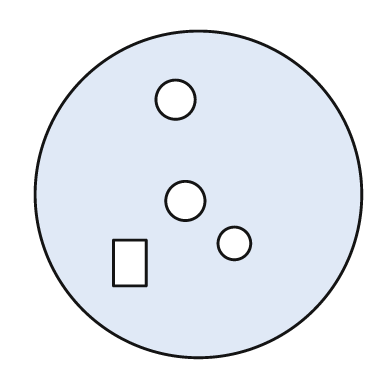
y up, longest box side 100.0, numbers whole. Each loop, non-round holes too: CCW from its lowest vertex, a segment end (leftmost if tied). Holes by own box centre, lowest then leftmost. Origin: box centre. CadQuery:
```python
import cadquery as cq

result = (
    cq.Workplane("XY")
    .moveTo(0.0, 0.0)
    .circle(50.0)
    .moveTo(-26.0, -28.0)
    .lineTo(-16.0, -28.0)
    .lineTo(-16.0, -14.0)
    .lineTo(-26.0, -14.0)
    .close()
    .moveTo(11.0, -15.0)
    .circle(5.0)
    .moveTo(-4.0, -2.0)
    .circle(6.0)
    .moveTo(-7.0, 29.0)
    .circle(6.0)
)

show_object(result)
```